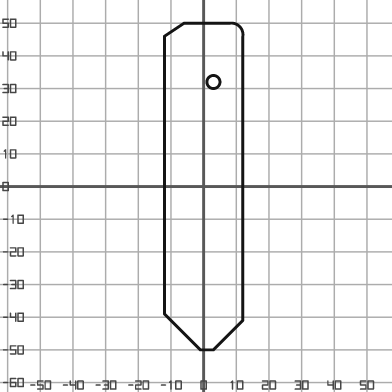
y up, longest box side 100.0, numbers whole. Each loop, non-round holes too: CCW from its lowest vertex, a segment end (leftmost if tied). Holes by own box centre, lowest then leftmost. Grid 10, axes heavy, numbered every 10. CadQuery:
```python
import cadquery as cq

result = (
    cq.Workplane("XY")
    .moveTo(-1.0, -50.0)
    .lineTo(3.0, -50.0)
    .lineTo(12.0, -41.0)
    .lineTo(12.0, 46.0)
    .threePointArc((11.0, 49.0), (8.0, 50.0))
    .lineTo(-6.0, 50.0)
    .lineTo(-12.0, 46.0)
    .lineTo(-12.0, -39.0)
    .close()
    .moveTo(3.0, 32.0)
    .circle(2.0)
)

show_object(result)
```